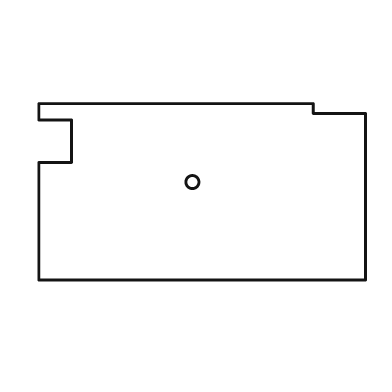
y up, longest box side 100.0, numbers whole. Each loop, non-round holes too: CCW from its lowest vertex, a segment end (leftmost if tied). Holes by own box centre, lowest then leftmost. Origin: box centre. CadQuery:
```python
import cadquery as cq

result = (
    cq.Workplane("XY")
    .moveTo(-50.0, -27.0)
    .lineTo(50.0, -27.0)
    .lineTo(50.0, 24.0)
    .lineTo(34.0, 24.0)
    .lineTo(34.0, 27.0)
    .lineTo(-50.0, 27.0)
    .lineTo(-50.0, 22.0)
    .lineTo(-40.0, 22.0)
    .lineTo(-40.0, 9.0)
    .lineTo(-50.0, 9.0)
    .close()
    .moveTo(-3.0, 3.0)
    .circle(2.0)
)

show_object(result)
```